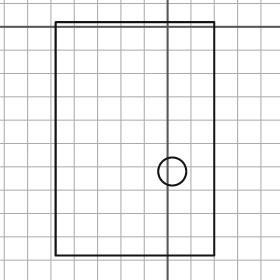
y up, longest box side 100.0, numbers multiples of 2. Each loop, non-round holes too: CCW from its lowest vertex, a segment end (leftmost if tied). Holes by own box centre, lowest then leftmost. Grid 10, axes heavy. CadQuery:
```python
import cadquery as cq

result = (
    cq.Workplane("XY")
    .moveTo(-48.0, -98.0)
    .lineTo(20.0, -98.0)
    .lineTo(20.0, 2.0)
    .lineTo(-48.0, 2.0)
    .close()
    .moveTo(2.0, -62.0)
    .circle(6.0)
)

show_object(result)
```